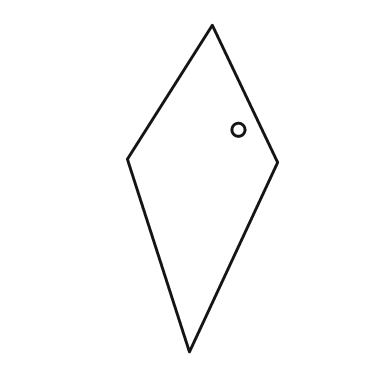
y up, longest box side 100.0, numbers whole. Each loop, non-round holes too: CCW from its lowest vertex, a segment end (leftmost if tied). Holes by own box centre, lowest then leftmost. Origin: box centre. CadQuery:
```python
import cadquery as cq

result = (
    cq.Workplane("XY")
    .moveTo(-4.0, -50.0)
    .lineTo(23.0, 8.0)
    .lineTo(3.0, 50.0)
    .lineTo(-23.0, 9.0)
    .close()
    .moveTo(11.0, 18.0)
    .circle(2.0)
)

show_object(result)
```